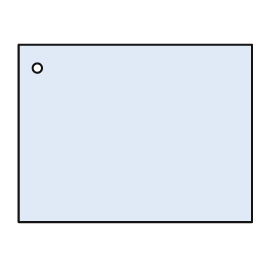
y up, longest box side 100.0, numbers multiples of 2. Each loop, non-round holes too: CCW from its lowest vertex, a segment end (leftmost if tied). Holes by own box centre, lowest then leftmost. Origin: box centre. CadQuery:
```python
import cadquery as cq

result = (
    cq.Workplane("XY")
    .moveTo(-50.0, -38.0)
    .lineTo(50.0, -38.0)
    .lineTo(50.0, 38.0)
    .lineTo(-50.0, 38.0)
    .close()
    .moveTo(-42.0, 28.0)
    .circle(2.0)
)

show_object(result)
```